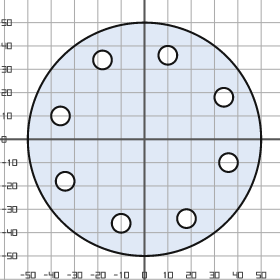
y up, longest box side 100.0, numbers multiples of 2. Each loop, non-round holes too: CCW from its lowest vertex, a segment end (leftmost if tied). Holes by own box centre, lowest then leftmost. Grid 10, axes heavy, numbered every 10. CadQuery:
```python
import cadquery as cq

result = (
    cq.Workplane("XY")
    .moveTo(0.0, 0.0)
    .circle(50.0)
    .moveTo(-10.0, -36.0)
    .circle(4.0)
    .moveTo(18.0, -34.0)
    .circle(4.0)
    .moveTo(-34.0, -18.0)
    .circle(4.0)
    .moveTo(36.0, -10.0)
    .circle(4.0)
    .moveTo(-36.0, 10.0)
    .circle(4.0)
    .moveTo(34.0, 18.0)
    .circle(4.0)
    .moveTo(-18.0, 34.0)
    .circle(4.0)
    .moveTo(10.0, 36.0)
    .circle(4.0)
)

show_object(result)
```